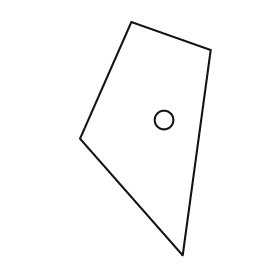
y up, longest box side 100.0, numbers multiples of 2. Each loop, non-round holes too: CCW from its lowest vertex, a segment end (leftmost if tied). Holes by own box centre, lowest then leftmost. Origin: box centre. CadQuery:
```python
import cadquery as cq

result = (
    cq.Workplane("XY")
    .moveTo(16.0, -50.0)
    .lineTo(28.0, 38.0)
    .lineTo(-6.0, 50.0)
    .lineTo(-28.0, 0.0)
    .close()
    .moveTo(8.0, 8.0)
    .circle(4.0)
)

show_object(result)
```